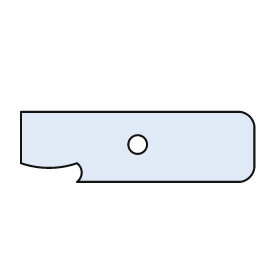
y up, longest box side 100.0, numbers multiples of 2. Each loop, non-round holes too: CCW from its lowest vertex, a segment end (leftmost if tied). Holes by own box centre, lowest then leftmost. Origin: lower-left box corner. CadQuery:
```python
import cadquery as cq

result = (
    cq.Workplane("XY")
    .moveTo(24.0, 0.0)
    .lineTo(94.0, 0.0)
    .threePointArc((98.0, 2.0), (100.0, 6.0))
    .lineTo(100.0, 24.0)
    .threePointArc((98.0, 28.0), (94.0, 30.0))
    .lineTo(0.0, 30.0)
    .lineTo(0.0, 8.0)
    .threePointArc((12.0, 6.0), (24.0, 8.0))
    .threePointArc((26.0, 4.0), (24.0, 0.0))
    .close()
    .moveTo(50.0, 16.0)
    .circle(4.0)
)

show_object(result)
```